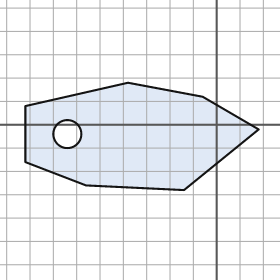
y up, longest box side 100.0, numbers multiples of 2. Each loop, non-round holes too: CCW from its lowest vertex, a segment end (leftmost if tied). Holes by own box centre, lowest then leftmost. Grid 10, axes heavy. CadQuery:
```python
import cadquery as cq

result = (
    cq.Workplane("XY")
    .moveTo(-14.0, -28.0)
    .lineTo(18.0, -2.0)
    .lineTo(-6.0, 12.0)
    .lineTo(-38.0, 18.0)
    .lineTo(-82.0, 8.0)
    .lineTo(-82.0, -16.0)
    .lineTo(-56.0, -26.0)
    .close()
    .moveTo(-64.0, -4.0)
    .circle(6.0)
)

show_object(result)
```